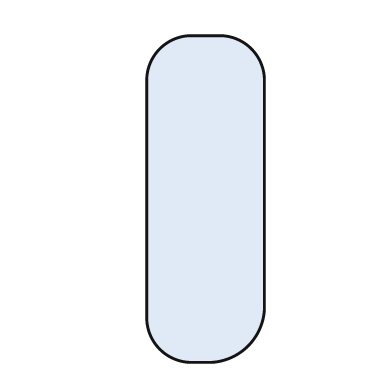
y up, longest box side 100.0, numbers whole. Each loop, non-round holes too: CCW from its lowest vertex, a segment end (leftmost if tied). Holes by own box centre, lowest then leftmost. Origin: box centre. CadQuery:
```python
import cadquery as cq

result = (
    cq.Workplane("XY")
    .moveTo(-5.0, -50.0)
    .lineTo(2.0, -50.0)
    .threePointArc((13.0, -45.0), (18.0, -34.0))
    .lineTo(18.0, 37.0)
    .threePointArc((14.0, 46.0), (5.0, 50.0))
    .lineTo(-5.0, 50.0)
    .threePointArc((-14.0, 46.0), (-18.0, 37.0))
    .lineTo(-18.0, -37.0)
    .threePointArc((-14.0, -46.0), (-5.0, -50.0))
    .close()
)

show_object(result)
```